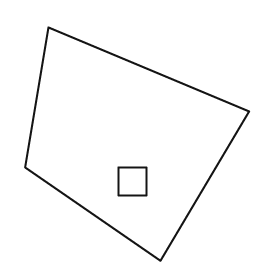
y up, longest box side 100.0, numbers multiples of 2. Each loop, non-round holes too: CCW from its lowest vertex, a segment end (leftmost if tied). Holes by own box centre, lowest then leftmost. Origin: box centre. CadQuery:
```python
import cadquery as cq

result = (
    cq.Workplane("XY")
    .moveTo(10.0, -50.0)
    .lineTo(48.0, 14.0)
    .lineTo(-38.0, 50.0)
    .lineTo(-48.0, -10.0)
    .close()
    .moveTo(-8.0, -22.0)
    .lineTo(4.0, -22.0)
    .lineTo(4.0, -10.0)
    .lineTo(-8.0, -10.0)
    .close()
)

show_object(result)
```